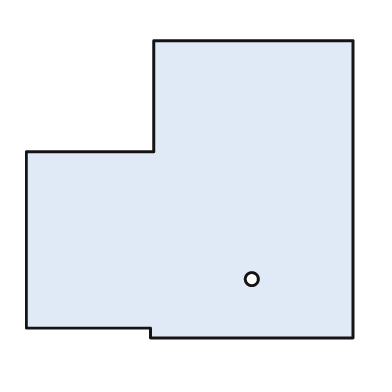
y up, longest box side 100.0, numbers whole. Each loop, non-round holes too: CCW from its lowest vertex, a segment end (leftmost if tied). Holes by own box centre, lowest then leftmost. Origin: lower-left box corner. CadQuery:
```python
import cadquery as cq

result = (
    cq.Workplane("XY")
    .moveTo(38.0, 0.0)
    .lineTo(100.0, 0.0)
    .lineTo(100.0, 91.0)
    .lineTo(39.0, 91.0)
    .lineTo(39.0, 57.0)
    .lineTo(0.0, 57.0)
    .lineTo(0.0, 3.0)
    .lineTo(38.0, 3.0)
    .close()
    .moveTo(69.0, 18.0)
    .circle(2.0)
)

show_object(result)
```